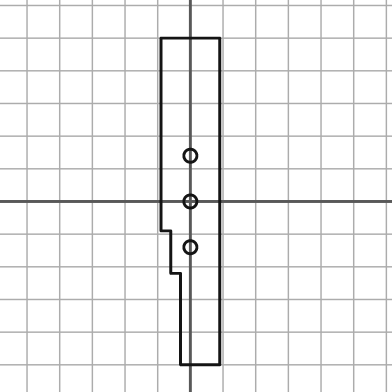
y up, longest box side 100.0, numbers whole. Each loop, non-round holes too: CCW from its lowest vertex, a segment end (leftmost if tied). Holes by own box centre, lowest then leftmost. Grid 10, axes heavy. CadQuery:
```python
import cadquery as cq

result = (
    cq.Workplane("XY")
    .moveTo(-3.0, -50.0)
    .lineTo(9.0, -50.0)
    .lineTo(9.0, 50.0)
    .lineTo(-9.0, 50.0)
    .lineTo(-9.0, -9.0)
    .lineTo(-6.0, -9.0)
    .lineTo(-6.0, -22.0)
    .lineTo(-3.0, -22.0)
    .close()
    .moveTo(0.0, -14.0)
    .circle(2.0)
    .moveTo(0.0, 0.0)
    .circle(2.0)
    .moveTo(0.0, 14.0)
    .circle(2.0)
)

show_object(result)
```